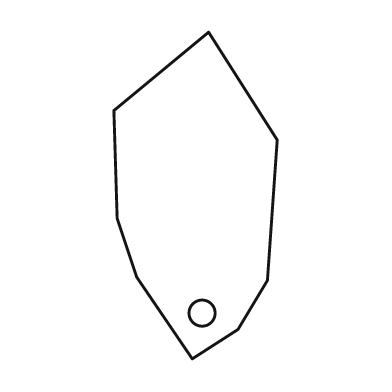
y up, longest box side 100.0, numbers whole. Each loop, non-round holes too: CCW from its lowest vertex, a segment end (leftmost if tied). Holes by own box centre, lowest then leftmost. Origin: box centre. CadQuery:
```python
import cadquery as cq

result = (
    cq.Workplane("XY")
    .moveTo(-1.0, -50.0)
    .lineTo(13.0, -41.0)
    .lineTo(22.0, -26.0)
    .lineTo(25.0, 17.0)
    .lineTo(4.0, 50.0)
    .lineTo(-25.0, 26.0)
    .lineTo(-24.0, -7.0)
    .lineTo(-18.0, -25.0)
    .close()
    .moveTo(2.0, -36.0)
    .circle(4.0)
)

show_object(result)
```